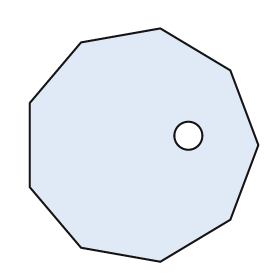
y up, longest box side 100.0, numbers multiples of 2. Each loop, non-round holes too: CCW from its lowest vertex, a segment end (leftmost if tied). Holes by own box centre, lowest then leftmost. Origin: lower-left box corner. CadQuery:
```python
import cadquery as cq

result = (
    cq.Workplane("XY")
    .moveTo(56.0, 0.0)
    .lineTo(86.0, 18.0)
    .lineTo(98.0, 50.0)
    .lineTo(86.0, 82.0)
    .lineTo(56.0, 100.0)
    .lineTo(22.0, 94.0)
    .lineTo(0.0, 68.0)
    .lineTo(0.0, 32.0)
    .lineTo(22.0, 6.0)
    .close()
    .moveTo(68.0, 54.0)
    .circle(6.0)
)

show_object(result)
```